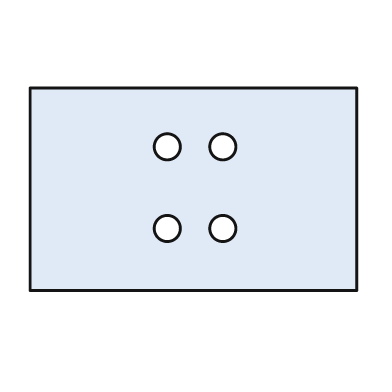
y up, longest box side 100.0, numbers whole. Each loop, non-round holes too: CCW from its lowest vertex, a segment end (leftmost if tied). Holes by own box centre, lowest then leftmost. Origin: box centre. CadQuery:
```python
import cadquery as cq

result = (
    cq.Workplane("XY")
    .moveTo(-50.0, -31.0)
    .lineTo(50.0, -31.0)
    .lineTo(50.0, 31.0)
    .lineTo(-50.0, 31.0)
    .close()
    .moveTo(-8.0, -12.0)
    .circle(4.0)
    .moveTo(9.0, -12.0)
    .circle(4.0)
    .moveTo(-8.0, 13.0)
    .circle(4.0)
    .moveTo(9.0, 13.0)
    .circle(4.0)
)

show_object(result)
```